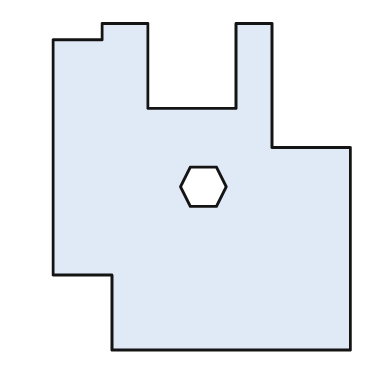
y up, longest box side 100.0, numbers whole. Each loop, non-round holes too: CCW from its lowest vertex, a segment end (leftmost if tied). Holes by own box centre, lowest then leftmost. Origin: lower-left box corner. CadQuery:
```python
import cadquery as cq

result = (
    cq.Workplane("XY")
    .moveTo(18.0, 0.0)
    .lineTo(91.0, 0.0)
    .lineTo(91.0, 62.0)
    .lineTo(67.0, 62.0)
    .lineTo(67.0, 100.0)
    .lineTo(56.0, 100.0)
    .lineTo(56.0, 74.0)
    .lineTo(29.0, 74.0)
    .lineTo(29.0, 100.0)
    .lineTo(15.0, 100.0)
    .lineTo(15.0, 95.0)
    .lineTo(0.0, 95.0)
    .lineTo(0.0, 23.0)
    .lineTo(18.0, 23.0)
    .close()
    .moveTo(42.0, 44.0)
    .lineTo(50.0, 44.0)
    .lineTo(53.0, 50.0)
    .lineTo(50.0, 56.0)
    .lineTo(42.0, 56.0)
    .lineTo(39.0, 50.0)
    .close()
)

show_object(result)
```